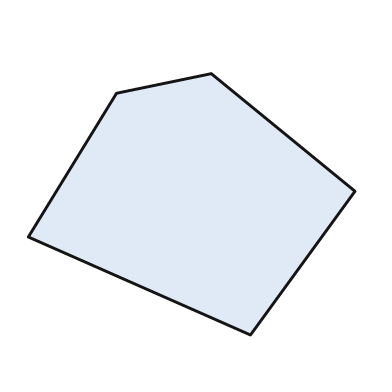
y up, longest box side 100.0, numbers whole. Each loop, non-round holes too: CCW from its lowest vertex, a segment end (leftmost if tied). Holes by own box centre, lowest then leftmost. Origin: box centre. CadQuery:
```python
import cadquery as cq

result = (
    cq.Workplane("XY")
    .moveTo(18.0, -40.0)
    .lineTo(50.0, 4.0)
    .lineTo(6.0, 40.0)
    .lineTo(-23.0, 34.0)
    .lineTo(-50.0, -10.0)
    .close()
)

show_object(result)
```